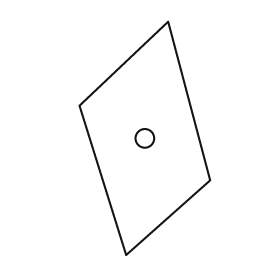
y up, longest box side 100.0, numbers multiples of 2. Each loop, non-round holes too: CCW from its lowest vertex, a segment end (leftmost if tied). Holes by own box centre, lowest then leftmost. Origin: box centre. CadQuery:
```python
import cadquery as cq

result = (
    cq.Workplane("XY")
    .moveTo(-8.0, -50.0)
    .lineTo(28.0, -18.0)
    .lineTo(10.0, 50.0)
    .lineTo(-28.0, 14.0)
    .close()
    .moveTo(0.0, 0.0)
    .circle(4.0)
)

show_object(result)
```